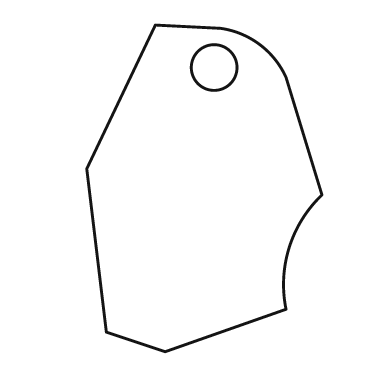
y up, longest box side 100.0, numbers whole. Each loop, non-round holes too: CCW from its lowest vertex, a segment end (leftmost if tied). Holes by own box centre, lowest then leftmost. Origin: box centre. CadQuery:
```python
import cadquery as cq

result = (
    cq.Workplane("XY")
    .moveTo(-12.0, -50.0)
    .lineTo(25.0, -37.0)
    .threePointArc((26.0, -18.0), (36.0, -2.0))
    .lineTo(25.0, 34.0)
    .threePointArc((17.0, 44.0), (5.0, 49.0))
    .lineTo(-15.0, 50.0)
    .lineTo(-36.0, 6.0)
    .lineTo(-30.0, -44.0)
    .close()
    .moveTo(3.0, 37.0)
    .circle(7.0)
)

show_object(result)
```